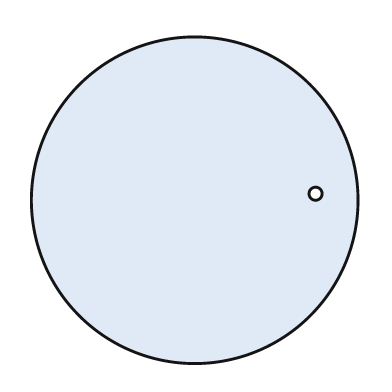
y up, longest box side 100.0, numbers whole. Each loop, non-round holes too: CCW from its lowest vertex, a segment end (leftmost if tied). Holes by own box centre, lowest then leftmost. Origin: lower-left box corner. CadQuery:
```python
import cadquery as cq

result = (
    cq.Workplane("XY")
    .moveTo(50.0, 50.0)
    .circle(50.0)
    .moveTo(87.0, 52.0)
    .circle(2.0)
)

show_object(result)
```